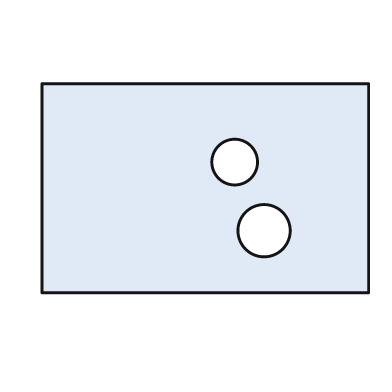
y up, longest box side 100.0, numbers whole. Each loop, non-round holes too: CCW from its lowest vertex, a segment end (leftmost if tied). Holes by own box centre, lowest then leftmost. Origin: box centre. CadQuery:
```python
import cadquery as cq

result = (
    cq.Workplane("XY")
    .moveTo(-50.0, -32.0)
    .lineTo(50.0, -32.0)
    .lineTo(50.0, 32.0)
    .lineTo(-50.0, 32.0)
    .close()
    .moveTo(18.0, -13.0)
    .circle(8.0)
    .moveTo(9.0, 8.0)
    .circle(7.0)
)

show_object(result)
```